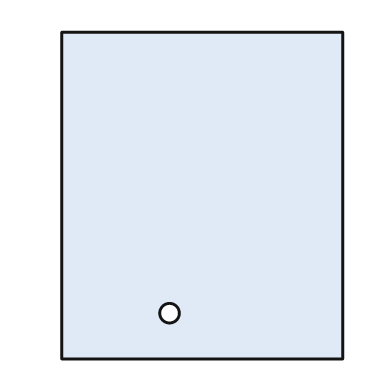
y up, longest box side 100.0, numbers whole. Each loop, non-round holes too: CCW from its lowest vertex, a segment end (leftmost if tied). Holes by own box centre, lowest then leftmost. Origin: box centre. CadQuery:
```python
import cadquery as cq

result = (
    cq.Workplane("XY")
    .moveTo(-43.0, -50.0)
    .lineTo(43.0, -50.0)
    .lineTo(43.0, 50.0)
    .lineTo(-43.0, 50.0)
    .close()
    .moveTo(-10.0, -36.0)
    .circle(3.0)
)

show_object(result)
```